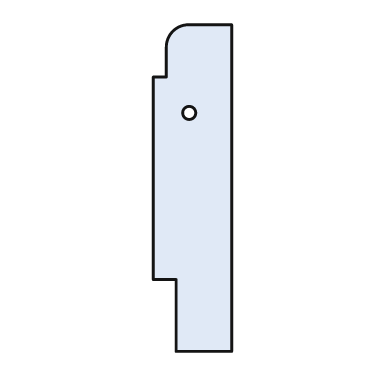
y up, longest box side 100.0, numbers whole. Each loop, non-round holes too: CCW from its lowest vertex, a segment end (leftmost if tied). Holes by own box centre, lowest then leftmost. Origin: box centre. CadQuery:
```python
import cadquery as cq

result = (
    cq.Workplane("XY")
    .moveTo(-5.0, -50.0)
    .lineTo(12.0, -50.0)
    .lineTo(12.0, 50.0)
    .lineTo(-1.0, 50.0)
    .threePointArc((-6.0, 48.0), (-8.0, 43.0))
    .lineTo(-8.0, 34.0)
    .lineTo(-12.0, 34.0)
    .lineTo(-12.0, -28.0)
    .lineTo(-5.0, -28.0)
    .close()
    .moveTo(-1.0, 23.0)
    .circle(2.0)
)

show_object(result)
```